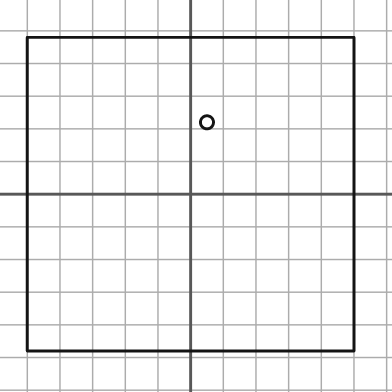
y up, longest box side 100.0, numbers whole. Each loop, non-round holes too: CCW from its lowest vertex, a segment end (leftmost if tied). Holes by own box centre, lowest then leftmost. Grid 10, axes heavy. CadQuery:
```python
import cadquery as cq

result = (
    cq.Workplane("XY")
    .moveTo(-50.0, -48.0)
    .lineTo(50.0, -48.0)
    .lineTo(50.0, 48.0)
    .lineTo(-50.0, 48.0)
    .close()
    .moveTo(5.0, 22.0)
    .circle(2.0)
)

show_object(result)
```